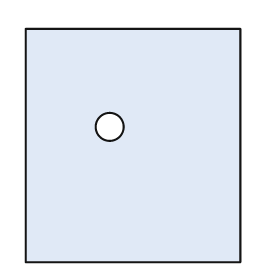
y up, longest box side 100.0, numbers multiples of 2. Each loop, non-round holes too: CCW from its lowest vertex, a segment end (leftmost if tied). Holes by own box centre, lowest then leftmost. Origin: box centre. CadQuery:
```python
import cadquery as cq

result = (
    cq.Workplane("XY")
    .moveTo(-46.0, -50.0)
    .lineTo(46.0, -50.0)
    .lineTo(46.0, 50.0)
    .lineTo(-46.0, 50.0)
    .close()
    .moveTo(-10.0, 8.0)
    .circle(6.0)
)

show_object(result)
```